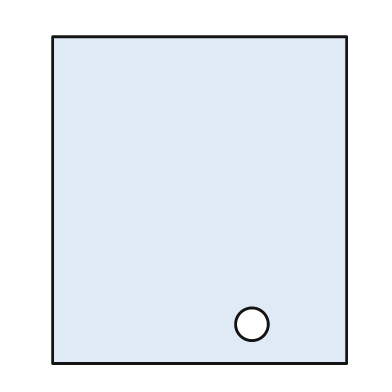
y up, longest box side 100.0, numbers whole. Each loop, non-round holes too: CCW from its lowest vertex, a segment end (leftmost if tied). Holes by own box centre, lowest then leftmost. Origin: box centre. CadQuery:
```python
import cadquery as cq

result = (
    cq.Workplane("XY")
    .moveTo(-45.0, -50.0)
    .lineTo(45.0, -50.0)
    .lineTo(45.0, 50.0)
    .lineTo(-45.0, 50.0)
    .close()
    .moveTo(16.0, -38.0)
    .circle(5.0)
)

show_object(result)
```